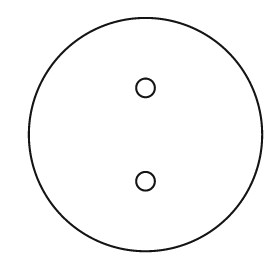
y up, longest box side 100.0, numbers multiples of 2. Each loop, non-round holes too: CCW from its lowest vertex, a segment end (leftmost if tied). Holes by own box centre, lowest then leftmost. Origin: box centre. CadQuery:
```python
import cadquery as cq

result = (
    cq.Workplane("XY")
    .moveTo(0.0, 0.0)
    .circle(50.0)
    .moveTo(0.0, -20.0)
    .circle(4.0)
    .moveTo(0.0, 20.0)
    .circle(4.0)
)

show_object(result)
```